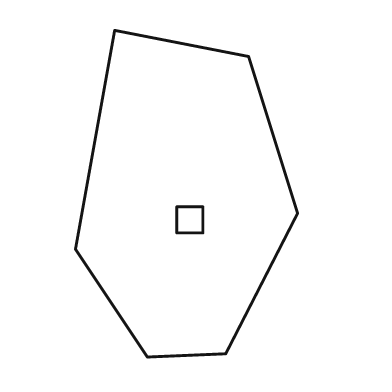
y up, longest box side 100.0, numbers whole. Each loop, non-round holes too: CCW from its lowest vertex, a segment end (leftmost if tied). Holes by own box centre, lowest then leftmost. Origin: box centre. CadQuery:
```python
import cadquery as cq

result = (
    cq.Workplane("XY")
    .moveTo(-12.0, -50.0)
    .lineTo(12.0, -49.0)
    .lineTo(34.0, -6.0)
    .lineTo(19.0, 42.0)
    .lineTo(-22.0, 50.0)
    .lineTo(-34.0, -17.0)
    .close()
    .moveTo(-3.0, -12.0)
    .lineTo(5.0, -12.0)
    .lineTo(5.0, -4.0)
    .lineTo(-3.0, -4.0)
    .close()
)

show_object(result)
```